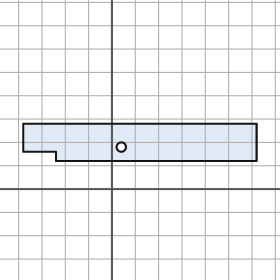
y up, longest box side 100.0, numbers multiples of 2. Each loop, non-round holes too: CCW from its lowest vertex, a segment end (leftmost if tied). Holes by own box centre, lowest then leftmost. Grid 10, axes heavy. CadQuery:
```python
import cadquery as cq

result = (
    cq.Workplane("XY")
    .moveTo(-24.0, 12.0)
    .lineTo(62.0, 12.0)
    .lineTo(62.0, 28.0)
    .lineTo(-38.0, 28.0)
    .lineTo(-38.0, 16.0)
    .lineTo(-24.0, 16.0)
    .close()
    .moveTo(4.0, 18.0)
    .circle(2.0)
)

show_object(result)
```